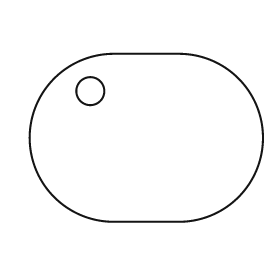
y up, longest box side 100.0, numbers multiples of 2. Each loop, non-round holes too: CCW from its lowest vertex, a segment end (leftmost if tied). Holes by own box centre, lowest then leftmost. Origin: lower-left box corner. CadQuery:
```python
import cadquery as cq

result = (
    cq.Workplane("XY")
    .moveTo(36.0, 0.0)
    .lineTo(64.0, 0.0)
    .threePointArc((100.0, 36.0), (64.0, 72.0))
    .lineTo(36.0, 72.0)
    .threePointArc((0.0, 36.0), (36.0, 0.0))
    .close()
    .moveTo(26.0, 56.0)
    .circle(6.0)
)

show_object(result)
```